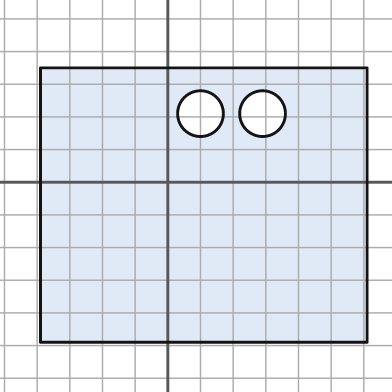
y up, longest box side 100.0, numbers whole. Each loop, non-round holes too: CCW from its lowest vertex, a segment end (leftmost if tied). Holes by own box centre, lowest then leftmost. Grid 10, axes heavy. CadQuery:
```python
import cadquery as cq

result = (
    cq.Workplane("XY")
    .moveTo(-39.0, -49.0)
    .lineTo(61.0, -49.0)
    .lineTo(61.0, 35.0)
    .lineTo(-39.0, 35.0)
    .close()
    .moveTo(10.0, 21.0)
    .circle(7.0)
    .moveTo(29.0, 21.0)
    .circle(7.0)
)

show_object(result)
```